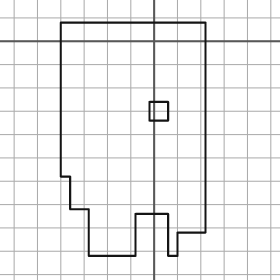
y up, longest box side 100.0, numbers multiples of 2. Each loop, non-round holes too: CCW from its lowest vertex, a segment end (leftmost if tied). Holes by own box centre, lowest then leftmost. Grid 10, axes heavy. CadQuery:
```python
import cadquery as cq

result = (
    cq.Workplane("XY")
    .moveTo(-28.0, -92.0)
    .lineTo(-8.0, -92.0)
    .lineTo(-8.0, -74.0)
    .lineTo(6.0, -74.0)
    .lineTo(6.0, -92.0)
    .lineTo(10.0, -92.0)
    .lineTo(10.0, -82.0)
    .lineTo(22.0, -82.0)
    .lineTo(22.0, 8.0)
    .lineTo(-40.0, 8.0)
    .lineTo(-40.0, -58.0)
    .lineTo(-36.0, -58.0)
    .lineTo(-36.0, -72.0)
    .lineTo(-28.0, -72.0)
    .close()
    .moveTo(-2.0, -34.0)
    .lineTo(6.0, -34.0)
    .lineTo(6.0, -26.0)
    .lineTo(-2.0, -26.0)
    .close()
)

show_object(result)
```